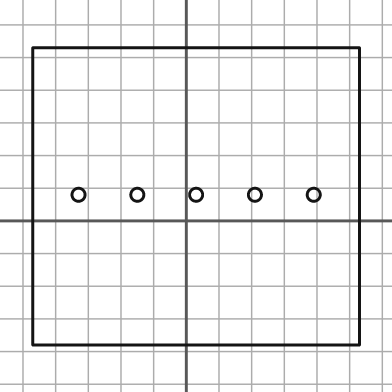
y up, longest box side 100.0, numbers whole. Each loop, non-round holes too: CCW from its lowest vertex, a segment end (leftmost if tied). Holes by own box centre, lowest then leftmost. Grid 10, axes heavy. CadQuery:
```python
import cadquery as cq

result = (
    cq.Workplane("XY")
    .moveTo(-47.0, -38.0)
    .lineTo(53.0, -38.0)
    .lineTo(53.0, 53.0)
    .lineTo(-47.0, 53.0)
    .close()
    .moveTo(-33.0, 8.0)
    .circle(2.0)
    .moveTo(-15.0, 8.0)
    .circle(2.0)
    .moveTo(3.0, 8.0)
    .circle(2.0)
    .moveTo(21.0, 8.0)
    .circle(2.0)
    .moveTo(39.0, 8.0)
    .circle(2.0)
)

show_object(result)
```